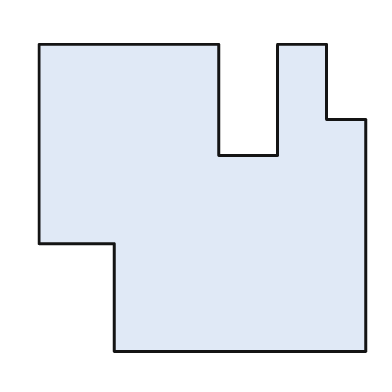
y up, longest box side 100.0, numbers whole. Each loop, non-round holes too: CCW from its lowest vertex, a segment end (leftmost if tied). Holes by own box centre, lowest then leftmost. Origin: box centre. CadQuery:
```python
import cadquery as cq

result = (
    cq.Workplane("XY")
    .moveTo(-27.0, -47.0)
    .lineTo(50.0, -47.0)
    .lineTo(50.0, 24.0)
    .lineTo(38.0, 24.0)
    .lineTo(38.0, 47.0)
    .lineTo(23.0, 47.0)
    .lineTo(23.0, 13.0)
    .lineTo(5.0, 13.0)
    .lineTo(5.0, 47.0)
    .lineTo(-50.0, 47.0)
    .lineTo(-50.0, -14.0)
    .lineTo(-27.0, -14.0)
    .close()
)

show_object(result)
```